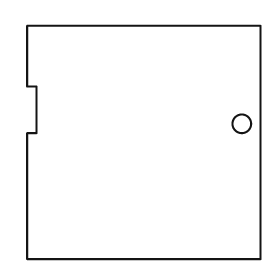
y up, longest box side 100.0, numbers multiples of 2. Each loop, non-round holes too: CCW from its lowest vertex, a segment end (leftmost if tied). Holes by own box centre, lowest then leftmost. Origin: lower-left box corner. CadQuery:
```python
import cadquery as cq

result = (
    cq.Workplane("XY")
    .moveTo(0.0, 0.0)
    .lineTo(100.0, 0.0)
    .lineTo(100.0, 100.0)
    .lineTo(0.0, 100.0)
    .lineTo(0.0, 74.0)
    .lineTo(4.0, 74.0)
    .lineTo(4.0, 54.0)
    .lineTo(0.0, 54.0)
    .close()
    .moveTo(92.0, 58.0)
    .circle(4.0)
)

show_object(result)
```